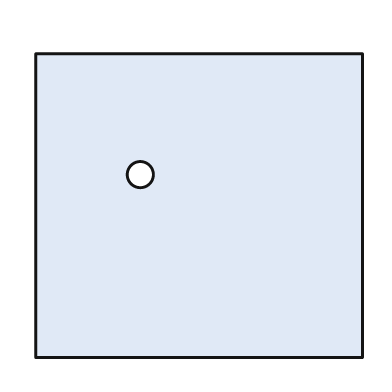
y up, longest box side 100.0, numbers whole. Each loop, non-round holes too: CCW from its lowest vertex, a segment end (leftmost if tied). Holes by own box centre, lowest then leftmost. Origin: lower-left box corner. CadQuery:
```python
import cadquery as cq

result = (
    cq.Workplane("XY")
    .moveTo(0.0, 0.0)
    .lineTo(100.0, 0.0)
    .lineTo(100.0, 93.0)
    .lineTo(0.0, 93.0)
    .close()
    .moveTo(32.0, 56.0)
    .circle(4.0)
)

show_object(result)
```